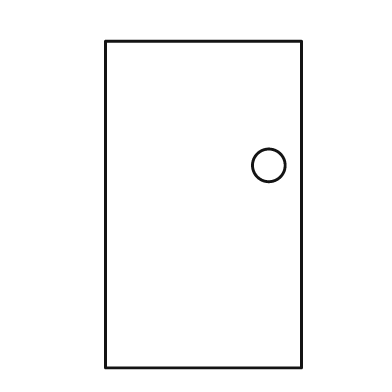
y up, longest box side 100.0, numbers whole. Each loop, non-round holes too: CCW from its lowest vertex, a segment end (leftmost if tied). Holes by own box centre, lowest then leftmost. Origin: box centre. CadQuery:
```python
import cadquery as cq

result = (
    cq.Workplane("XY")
    .moveTo(-30.0, -50.0)
    .lineTo(30.0, -50.0)
    .lineTo(30.0, 50.0)
    .lineTo(-30.0, 50.0)
    .close()
    .moveTo(20.0, 12.0)
    .circle(5.0)
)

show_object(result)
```